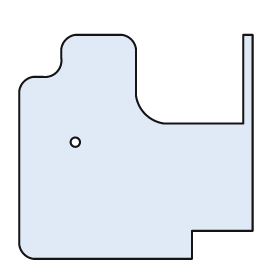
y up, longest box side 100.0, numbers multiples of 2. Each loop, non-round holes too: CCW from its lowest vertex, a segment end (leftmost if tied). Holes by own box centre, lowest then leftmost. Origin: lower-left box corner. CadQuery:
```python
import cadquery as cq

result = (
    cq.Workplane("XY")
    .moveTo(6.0, 0.0)
    .lineTo(74.0, 0.0)
    .lineTo(74.0, 12.0)
    .lineTo(100.0, 12.0)
    .lineTo(100.0, 96.0)
    .lineTo(96.0, 96.0)
    .lineTo(96.0, 58.0)
    .lineTo(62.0, 58.0)
    .threePointArc((54.0, 62.0), (50.0, 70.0))
    .lineTo(50.0, 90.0)
    .threePointArc((48.0, 94.0), (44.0, 96.0))
    .lineTo(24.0, 96.0)
    .threePointArc((20.0, 94.0), (18.0, 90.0))
    .lineTo(18.0, 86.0)
    .threePointArc((16.0, 80.0), (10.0, 78.0))
    .lineTo(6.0, 78.0)
    .threePointArc((2.0, 76.0), (0.0, 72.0))
    .lineTo(0.0, 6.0)
    .threePointArc((2.0, 2.0), (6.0, 0.0))
    .close()
    .moveTo(24.0, 50.0)
    .circle(2.0)
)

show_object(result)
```